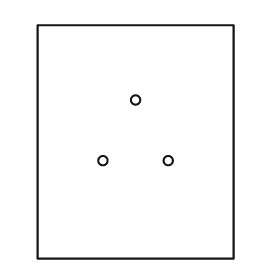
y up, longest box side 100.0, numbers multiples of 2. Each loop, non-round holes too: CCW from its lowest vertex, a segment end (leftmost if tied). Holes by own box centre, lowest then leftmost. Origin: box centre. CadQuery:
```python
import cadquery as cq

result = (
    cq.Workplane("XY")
    .moveTo(-42.0, -50.0)
    .lineTo(42.0, -50.0)
    .lineTo(42.0, 50.0)
    .lineTo(-42.0, 50.0)
    .close()
    .moveTo(-14.0, -8.0)
    .circle(2.0)
    .moveTo(14.0, -8.0)
    .circle(2.0)
    .moveTo(0.0, 18.0)
    .circle(2.0)
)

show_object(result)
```